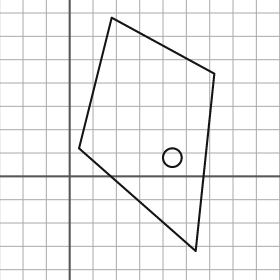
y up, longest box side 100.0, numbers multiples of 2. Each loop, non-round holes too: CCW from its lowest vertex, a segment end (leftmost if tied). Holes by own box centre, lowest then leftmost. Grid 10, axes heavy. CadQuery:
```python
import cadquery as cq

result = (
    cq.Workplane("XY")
    .moveTo(54.0, -32.0)
    .lineTo(62.0, 44.0)
    .lineTo(18.0, 68.0)
    .lineTo(4.0, 12.0)
    .close()
    .moveTo(44.0, 8.0)
    .circle(4.0)
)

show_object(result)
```